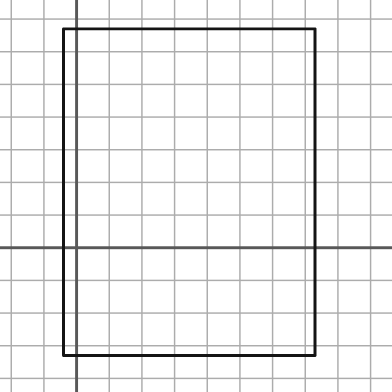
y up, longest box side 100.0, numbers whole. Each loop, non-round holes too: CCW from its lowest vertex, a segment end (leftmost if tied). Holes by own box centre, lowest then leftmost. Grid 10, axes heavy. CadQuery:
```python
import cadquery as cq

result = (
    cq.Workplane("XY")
    .moveTo(-4.0, -33.0)
    .lineTo(73.0, -33.0)
    .lineTo(73.0, 67.0)
    .lineTo(-4.0, 67.0)
    .close()
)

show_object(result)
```